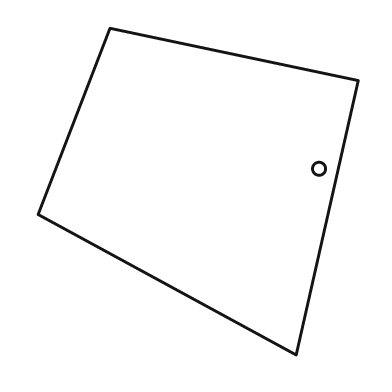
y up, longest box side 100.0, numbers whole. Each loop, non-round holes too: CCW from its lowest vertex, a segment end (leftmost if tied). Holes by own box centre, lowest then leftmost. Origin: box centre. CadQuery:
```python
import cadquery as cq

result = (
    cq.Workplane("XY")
    .moveTo(30.0, -50.0)
    .lineTo(49.0, 34.0)
    .lineTo(-27.0, 50.0)
    .lineTo(-49.0, -7.0)
    .close()
    .moveTo(37.0, 7.0)
    .circle(2.0)
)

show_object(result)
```